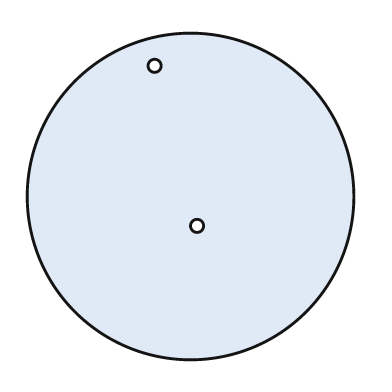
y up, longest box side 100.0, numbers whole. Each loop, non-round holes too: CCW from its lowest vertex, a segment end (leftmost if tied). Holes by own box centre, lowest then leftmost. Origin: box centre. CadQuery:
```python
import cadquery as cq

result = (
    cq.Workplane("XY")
    .moveTo(0.0, 0.0)
    .circle(50.0)
    .moveTo(2.0, -9.0)
    .circle(2.0)
    .moveTo(-11.0, 40.0)
    .circle(2.0)
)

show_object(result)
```